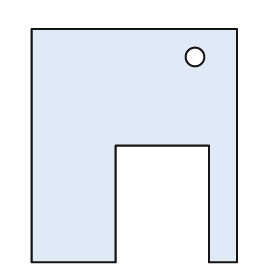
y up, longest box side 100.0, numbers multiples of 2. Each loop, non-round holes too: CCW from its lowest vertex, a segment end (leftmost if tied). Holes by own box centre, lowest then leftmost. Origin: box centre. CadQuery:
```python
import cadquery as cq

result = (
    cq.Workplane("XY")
    .moveTo(-44.0, -50.0)
    .lineTo(-8.0, -50.0)
    .lineTo(-8.0, 0.0)
    .lineTo(32.0, 0.0)
    .lineTo(32.0, -50.0)
    .lineTo(44.0, -50.0)
    .lineTo(44.0, 50.0)
    .lineTo(-44.0, 50.0)
    .close()
    .moveTo(26.0, 38.0)
    .circle(4.0)
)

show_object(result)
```